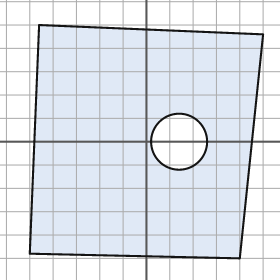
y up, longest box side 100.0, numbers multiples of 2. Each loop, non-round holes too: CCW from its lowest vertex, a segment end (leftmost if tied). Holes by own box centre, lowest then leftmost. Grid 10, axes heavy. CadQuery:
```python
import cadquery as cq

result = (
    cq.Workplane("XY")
    .moveTo(40.0, -50.0)
    .lineTo(50.0, 46.0)
    .lineTo(-46.0, 50.0)
    .lineTo(-50.0, -48.0)
    .close()
    .moveTo(14.0, 0.0)
    .circle(12.0)
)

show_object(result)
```